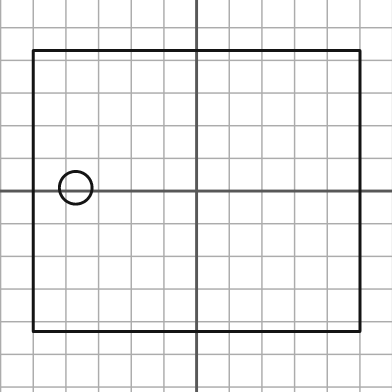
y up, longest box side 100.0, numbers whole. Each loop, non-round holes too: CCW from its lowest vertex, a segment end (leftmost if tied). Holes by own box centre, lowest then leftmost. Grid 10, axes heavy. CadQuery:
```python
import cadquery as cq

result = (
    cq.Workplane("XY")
    .moveTo(-50.0, -43.0)
    .lineTo(50.0, -43.0)
    .lineTo(50.0, 43.0)
    .lineTo(-50.0, 43.0)
    .close()
    .moveTo(-37.0, 1.0)
    .circle(5.0)
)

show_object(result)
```